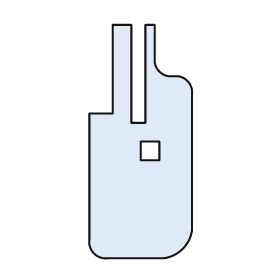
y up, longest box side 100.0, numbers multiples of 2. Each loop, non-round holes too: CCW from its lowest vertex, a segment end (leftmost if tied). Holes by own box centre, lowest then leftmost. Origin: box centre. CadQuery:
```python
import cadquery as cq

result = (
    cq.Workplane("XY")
    .moveTo(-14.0, -50.0)
    .lineTo(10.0, -50.0)
    .threePointArc((18.0, -46.0), (22.0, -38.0))
    .lineTo(22.0, 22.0)
    .threePointArc((20.0, 26.0), (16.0, 28.0))
    .lineTo(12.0, 28.0)
    .threePointArc((8.0, 30.0), (6.0, 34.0))
    .lineTo(6.0, 50.0)
    .lineTo(2.0, 50.0)
    .lineTo(2.0, 8.0)
    .lineTo(-4.0, 8.0)
    .lineTo(-4.0, 50.0)
    .lineTo(-12.0, 50.0)
    .lineTo(-12.0, 12.0)
    .lineTo(-22.0, 12.0)
    .lineTo(-22.0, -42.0)
    .threePointArc((-20.0, -48.0), (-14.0, -50.0))
    .close()
    .moveTo(0.0, -8.0)
    .lineTo(8.0, -8.0)
    .lineTo(8.0, 0.0)
    .lineTo(0.0, 0.0)
    .close()
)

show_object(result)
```